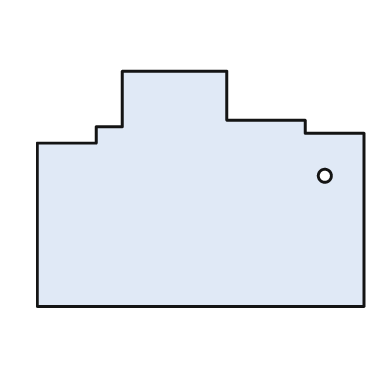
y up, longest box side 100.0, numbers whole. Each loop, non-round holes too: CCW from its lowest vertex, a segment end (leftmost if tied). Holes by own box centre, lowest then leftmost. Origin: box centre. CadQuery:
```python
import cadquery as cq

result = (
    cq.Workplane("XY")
    .moveTo(-50.0, -36.0)
    .lineTo(50.0, -36.0)
    .lineTo(50.0, 17.0)
    .lineTo(32.0, 17.0)
    .lineTo(32.0, 21.0)
    .lineTo(8.0, 21.0)
    .lineTo(8.0, 36.0)
    .lineTo(-24.0, 36.0)
    .lineTo(-24.0, 19.0)
    .lineTo(-32.0, 19.0)
    .lineTo(-32.0, 14.0)
    .lineTo(-50.0, 14.0)
    .close()
    .moveTo(38.0, 4.0)
    .circle(2.0)
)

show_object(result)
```